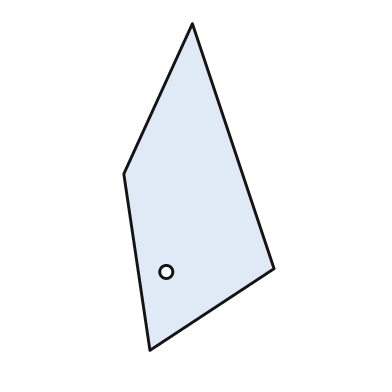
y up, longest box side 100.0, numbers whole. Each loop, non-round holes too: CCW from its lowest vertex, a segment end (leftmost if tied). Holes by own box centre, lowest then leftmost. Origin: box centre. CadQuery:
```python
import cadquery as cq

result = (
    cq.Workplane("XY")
    .moveTo(-15.0, -50.0)
    .lineTo(23.0, -25.0)
    .lineTo(-2.0, 50.0)
    .lineTo(-23.0, 4.0)
    .close()
    .moveTo(-10.0, -26.0)
    .circle(2.0)
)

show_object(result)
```